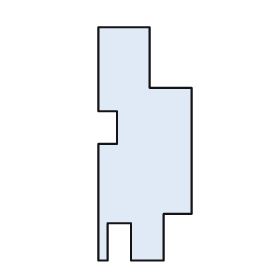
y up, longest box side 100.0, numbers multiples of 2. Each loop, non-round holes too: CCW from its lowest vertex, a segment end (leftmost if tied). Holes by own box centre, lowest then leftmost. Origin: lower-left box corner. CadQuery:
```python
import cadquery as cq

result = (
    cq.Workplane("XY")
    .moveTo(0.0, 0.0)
    .lineTo(4.0, 0.0)
    .lineTo(4.0, 16.0)
    .lineTo(14.0, 16.0)
    .lineTo(14.0, 0.0)
    .lineTo(28.0, 0.0)
    .lineTo(28.0, 20.0)
    .lineTo(40.0, 20.0)
    .lineTo(40.0, 74.0)
    .lineTo(22.0, 74.0)
    .lineTo(22.0, 100.0)
    .lineTo(0.0, 100.0)
    .lineTo(0.0, 64.0)
    .lineTo(8.0, 64.0)
    .lineTo(8.0, 50.0)
    .lineTo(0.0, 50.0)
    .close()
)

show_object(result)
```